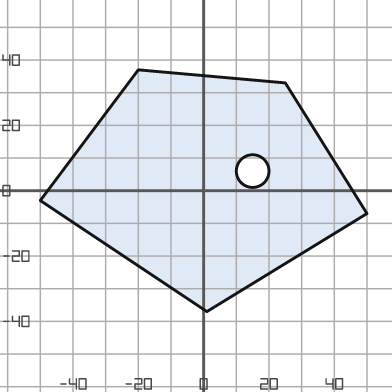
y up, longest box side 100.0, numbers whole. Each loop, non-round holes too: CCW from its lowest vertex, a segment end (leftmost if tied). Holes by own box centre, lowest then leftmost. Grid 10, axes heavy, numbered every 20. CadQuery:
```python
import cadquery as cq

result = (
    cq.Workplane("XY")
    .moveTo(1.0, -37.0)
    .lineTo(50.0, -7.0)
    .lineTo(25.0, 33.0)
    .lineTo(-20.0, 37.0)
    .lineTo(-50.0, -3.0)
    .close()
    .moveTo(15.0, 6.0)
    .circle(5.0)
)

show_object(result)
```